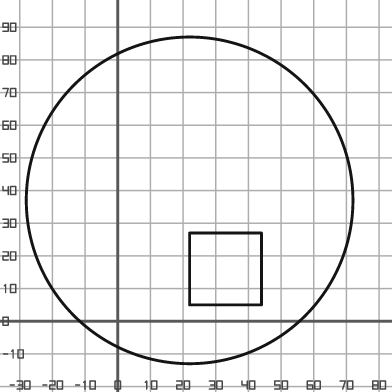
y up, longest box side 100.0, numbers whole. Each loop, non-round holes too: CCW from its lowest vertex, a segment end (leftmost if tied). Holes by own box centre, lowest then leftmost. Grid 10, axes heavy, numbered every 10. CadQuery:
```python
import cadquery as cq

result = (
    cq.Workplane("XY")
    .moveTo(22.0, 37.0)
    .circle(50.0)
    .moveTo(22.0, 5.0)
    .lineTo(44.0, 5.0)
    .lineTo(44.0, 27.0)
    .lineTo(22.0, 27.0)
    .close()
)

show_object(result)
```